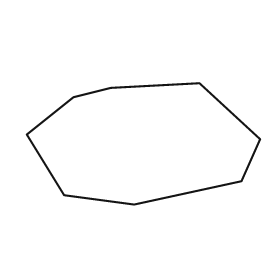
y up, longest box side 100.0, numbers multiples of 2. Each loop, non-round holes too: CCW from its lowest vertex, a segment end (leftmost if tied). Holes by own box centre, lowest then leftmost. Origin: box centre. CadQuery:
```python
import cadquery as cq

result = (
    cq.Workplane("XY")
    .moveTo(-4.0, -26.0)
    .lineTo(42.0, -16.0)
    .lineTo(50.0, 2.0)
    .lineTo(24.0, 26.0)
    .lineTo(-14.0, 24.0)
    .lineTo(-30.0, 20.0)
    .lineTo(-50.0, 4.0)
    .lineTo(-34.0, -22.0)
    .close()
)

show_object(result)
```